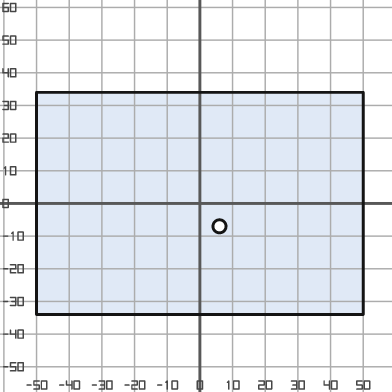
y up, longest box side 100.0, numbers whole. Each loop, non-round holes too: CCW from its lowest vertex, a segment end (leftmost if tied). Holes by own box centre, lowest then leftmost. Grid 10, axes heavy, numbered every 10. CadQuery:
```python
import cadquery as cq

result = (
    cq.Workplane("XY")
    .moveTo(-50.0, -34.0)
    .lineTo(50.0, -34.0)
    .lineTo(50.0, 34.0)
    .lineTo(-50.0, 34.0)
    .close()
    .moveTo(6.0, -7.0)
    .circle(2.0)
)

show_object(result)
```